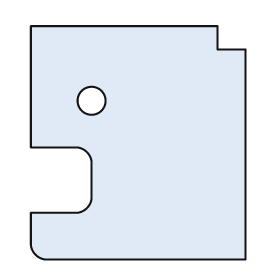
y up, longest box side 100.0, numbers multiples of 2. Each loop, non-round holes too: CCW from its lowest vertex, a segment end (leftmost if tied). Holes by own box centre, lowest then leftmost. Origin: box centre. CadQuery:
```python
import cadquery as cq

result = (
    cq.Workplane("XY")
    .moveTo(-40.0, -50.0)
    .lineTo(46.0, -50.0)
    .lineTo(46.0, 40.0)
    .lineTo(34.0, 40.0)
    .lineTo(34.0, 50.0)
    .lineTo(-46.0, 50.0)
    .lineTo(-46.0, -2.0)
    .lineTo(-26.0, -2.0)
    .threePointArc((-22.0, -4.0), (-20.0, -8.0))
    .lineTo(-20.0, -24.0)
    .threePointArc((-22.0, -28.0), (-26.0, -30.0))
    .lineTo(-46.0, -30.0)
    .lineTo(-46.0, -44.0)
    .threePointArc((-44.0, -48.0), (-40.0, -50.0))
    .close()
    .moveTo(-20.0, 18.0)
    .circle(6.0)
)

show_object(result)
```